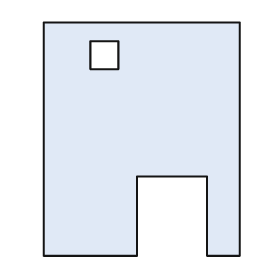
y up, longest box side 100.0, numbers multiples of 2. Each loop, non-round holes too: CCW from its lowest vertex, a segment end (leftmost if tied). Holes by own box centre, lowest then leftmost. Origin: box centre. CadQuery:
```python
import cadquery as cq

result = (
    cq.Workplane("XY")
    .moveTo(-42.0, -50.0)
    .lineTo(-2.0, -50.0)
    .lineTo(-2.0, -16.0)
    .lineTo(28.0, -16.0)
    .lineTo(28.0, -50.0)
    .lineTo(42.0, -50.0)
    .lineTo(42.0, 50.0)
    .lineTo(-42.0, 50.0)
    .close()
    .moveTo(-22.0, 30.0)
    .lineTo(-10.0, 30.0)
    .lineTo(-10.0, 42.0)
    .lineTo(-22.0, 42.0)
    .close()
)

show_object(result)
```